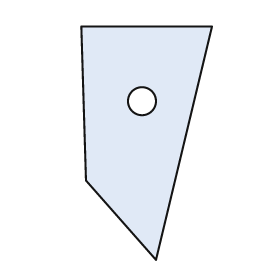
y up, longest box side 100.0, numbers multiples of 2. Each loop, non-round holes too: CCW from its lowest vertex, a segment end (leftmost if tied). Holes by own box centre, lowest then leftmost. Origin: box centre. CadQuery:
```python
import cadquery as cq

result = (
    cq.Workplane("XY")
    .moveTo(4.0, -50.0)
    .lineTo(28.0, 50.0)
    .lineTo(-28.0, 50.0)
    .lineTo(-26.0, -16.0)
    .close()
    .moveTo(-2.0, 18.0)
    .circle(6.0)
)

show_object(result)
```